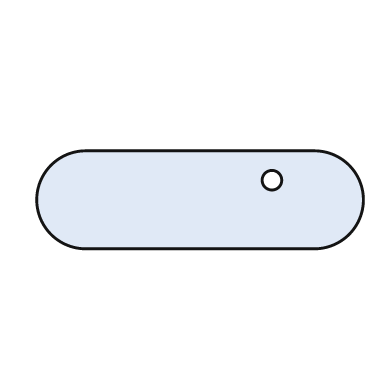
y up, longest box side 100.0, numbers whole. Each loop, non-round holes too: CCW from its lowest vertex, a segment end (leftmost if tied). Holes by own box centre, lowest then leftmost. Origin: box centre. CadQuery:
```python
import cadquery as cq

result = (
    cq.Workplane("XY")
    .moveTo(-35.0, -15.0)
    .lineTo(35.0, -15.0)
    .threePointArc((50.0, 0.0), (35.0, 15.0))
    .lineTo(-35.0, 15.0)
    .threePointArc((-50.0, 0.0), (-35.0, -15.0))
    .close()
    .moveTo(22.0, 6.0)
    .circle(3.0)
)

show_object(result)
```